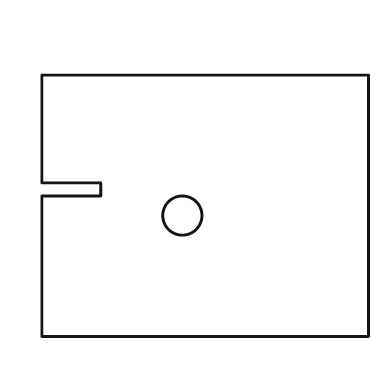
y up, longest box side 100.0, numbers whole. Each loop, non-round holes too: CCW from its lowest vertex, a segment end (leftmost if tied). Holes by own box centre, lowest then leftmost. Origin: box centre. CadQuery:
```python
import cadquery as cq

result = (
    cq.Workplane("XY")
    .moveTo(-50.0, -40.0)
    .lineTo(50.0, -40.0)
    .lineTo(50.0, 40.0)
    .lineTo(-50.0, 40.0)
    .lineTo(-50.0, 7.0)
    .lineTo(-32.0, 7.0)
    .lineTo(-32.0, 3.0)
    .lineTo(-50.0, 3.0)
    .close()
    .moveTo(-7.0, -3.0)
    .circle(6.0)
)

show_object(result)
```